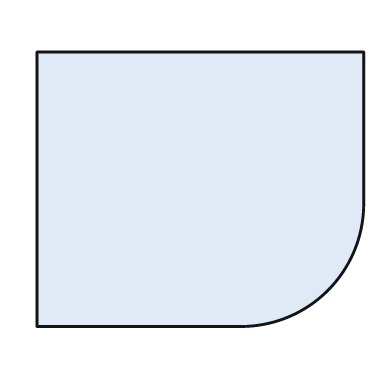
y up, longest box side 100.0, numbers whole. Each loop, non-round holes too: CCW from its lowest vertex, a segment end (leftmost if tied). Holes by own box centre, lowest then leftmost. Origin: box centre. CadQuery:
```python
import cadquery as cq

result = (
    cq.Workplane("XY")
    .moveTo(-50.0, -42.0)
    .lineTo(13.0, -42.0)
    .threePointArc((39.0, -31.0), (50.0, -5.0))
    .lineTo(50.0, 42.0)
    .lineTo(-50.0, 42.0)
    .close()
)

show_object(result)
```